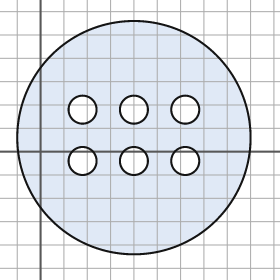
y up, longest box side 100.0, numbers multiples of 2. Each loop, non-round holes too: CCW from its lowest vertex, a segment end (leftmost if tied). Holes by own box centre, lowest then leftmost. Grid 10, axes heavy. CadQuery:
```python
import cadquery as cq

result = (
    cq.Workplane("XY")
    .moveTo(40.0, 6.0)
    .circle(50.0)
    .moveTo(18.0, -4.0)
    .circle(6.0)
    .moveTo(40.0, -4.0)
    .circle(6.0)
    .moveTo(62.0, -4.0)
    .circle(6.0)
    .moveTo(18.0, 18.0)
    .circle(6.0)
    .moveTo(40.0, 18.0)
    .circle(6.0)
    .moveTo(62.0, 18.0)
    .circle(6.0)
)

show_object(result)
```